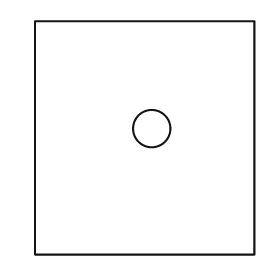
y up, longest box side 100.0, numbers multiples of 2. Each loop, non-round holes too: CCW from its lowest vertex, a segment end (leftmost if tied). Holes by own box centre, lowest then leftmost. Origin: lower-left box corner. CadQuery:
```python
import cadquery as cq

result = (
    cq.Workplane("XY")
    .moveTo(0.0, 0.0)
    .lineTo(94.0, 0.0)
    .lineTo(94.0, 100.0)
    .lineTo(0.0, 100.0)
    .close()
    .moveTo(50.0, 54.0)
    .circle(8.0)
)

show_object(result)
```